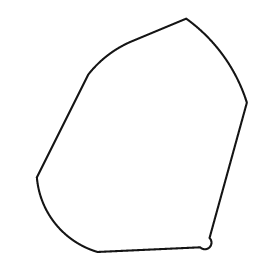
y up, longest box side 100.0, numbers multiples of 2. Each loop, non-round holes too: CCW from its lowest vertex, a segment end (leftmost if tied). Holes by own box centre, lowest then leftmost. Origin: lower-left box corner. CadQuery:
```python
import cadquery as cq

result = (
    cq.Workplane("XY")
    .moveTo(26.0, 0.0)
    .lineTo(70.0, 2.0)
    .threePointArc((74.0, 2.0), (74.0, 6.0))
    .lineTo(90.0, 64.0)
    .threePointArc((80.0, 84.0), (64.0, 100.0))
    .lineTo(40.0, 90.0)
    .threePointArc((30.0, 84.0), (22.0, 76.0))
    .lineTo(0.0, 32.0)
    .threePointArc((8.0, 12.0), (26.0, 0.0))
    .close()
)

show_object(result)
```